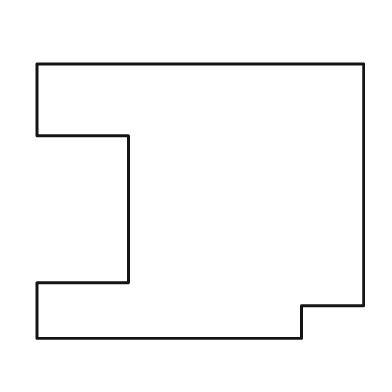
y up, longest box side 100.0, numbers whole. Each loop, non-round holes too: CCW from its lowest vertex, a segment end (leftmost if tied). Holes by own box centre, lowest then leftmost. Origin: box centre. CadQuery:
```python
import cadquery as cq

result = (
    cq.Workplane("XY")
    .moveTo(-50.0, -42.0)
    .lineTo(31.0, -42.0)
    .lineTo(31.0, -32.0)
    .lineTo(50.0, -32.0)
    .lineTo(50.0, 42.0)
    .lineTo(-50.0, 42.0)
    .lineTo(-50.0, 20.0)
    .lineTo(-22.0, 20.0)
    .lineTo(-22.0, -25.0)
    .lineTo(-50.0, -25.0)
    .close()
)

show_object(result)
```